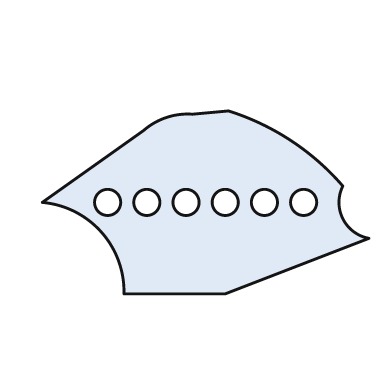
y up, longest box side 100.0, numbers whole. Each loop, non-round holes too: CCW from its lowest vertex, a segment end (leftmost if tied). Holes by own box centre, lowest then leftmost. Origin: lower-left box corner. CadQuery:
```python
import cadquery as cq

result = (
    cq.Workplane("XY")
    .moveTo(25.0, 0.0)
    .lineTo(56.0, 0.0)
    .lineTo(100.0, 17.0)
    .threePointArc((92.0, 23.0), (92.0, 33.0))
    .threePointArc((76.0, 47.0), (57.0, 56.0))
    .lineTo(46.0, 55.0)
    .threePointArc((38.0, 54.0), (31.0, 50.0))
    .lineTo(0.0, 28.0)
    .threePointArc((18.0, 19.0), (25.0, 0.0))
    .close()
    .moveTo(20.0, 28.0)
    .circle(4.0)
    .moveTo(32.0, 28.0)
    .circle(4.0)
    .moveTo(44.0, 28.0)
    .circle(4.0)
    .moveTo(56.0, 28.0)
    .circle(4.0)
    .moveTo(68.0, 28.0)
    .circle(4.0)
    .moveTo(80.0, 28.0)
    .circle(4.0)
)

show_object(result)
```